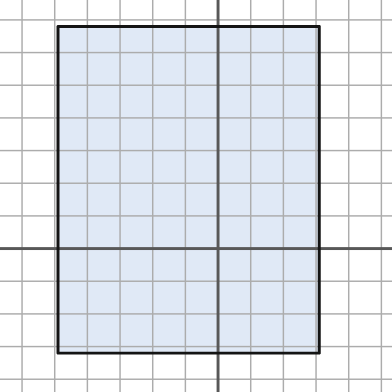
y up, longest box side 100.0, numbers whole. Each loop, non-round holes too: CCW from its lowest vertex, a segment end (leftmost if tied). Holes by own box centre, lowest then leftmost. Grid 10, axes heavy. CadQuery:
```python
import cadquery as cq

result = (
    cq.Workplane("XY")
    .moveTo(-49.0, -32.0)
    .lineTo(31.0, -32.0)
    .lineTo(31.0, 68.0)
    .lineTo(-49.0, 68.0)
    .close()
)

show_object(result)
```